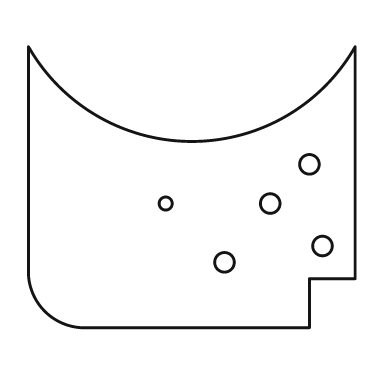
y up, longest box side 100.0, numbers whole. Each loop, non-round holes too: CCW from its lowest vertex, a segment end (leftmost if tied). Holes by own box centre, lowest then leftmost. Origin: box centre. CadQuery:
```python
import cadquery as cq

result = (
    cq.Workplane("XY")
    .moveTo(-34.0, -43.0)
    .lineTo(36.0, -43.0)
    .lineTo(36.0, -28.0)
    .lineTo(50.0, -28.0)
    .lineTo(50.0, 43.0)
    .threePointArc((0.0, 14.0), (-50.0, 43.0))
    .lineTo(-50.0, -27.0)
    .threePointArc((-45.0, -38.0), (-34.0, -43.0))
    .close()
    .moveTo(10.0, -23.0)
    .circle(3.0)
    .moveTo(40.0, -18.0)
    .circle(3.0)
    .moveTo(-8.0, -5.0)
    .circle(2.0)
    .moveTo(24.0, -5.0)
    .circle(3.0)
    .moveTo(36.0, 7.0)
    .circle(3.0)
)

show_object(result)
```